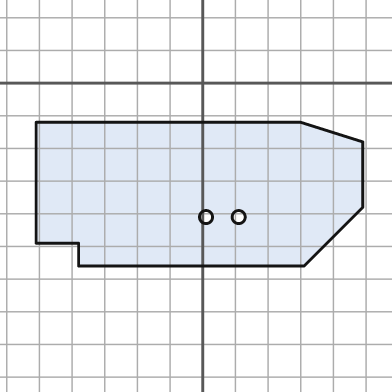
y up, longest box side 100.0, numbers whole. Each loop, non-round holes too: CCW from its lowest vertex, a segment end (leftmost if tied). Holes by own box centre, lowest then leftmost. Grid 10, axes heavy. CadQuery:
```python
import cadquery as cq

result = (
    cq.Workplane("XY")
    .moveTo(-38.0, -56.0)
    .lineTo(31.0, -56.0)
    .lineTo(49.0, -38.0)
    .lineTo(49.0, -18.0)
    .lineTo(30.0, -12.0)
    .lineTo(-51.0, -12.0)
    .lineTo(-51.0, -49.0)
    .lineTo(-38.0, -49.0)
    .close()
    .moveTo(1.0, -41.0)
    .circle(2.0)
    .moveTo(11.0, -41.0)
    .circle(2.0)
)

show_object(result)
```